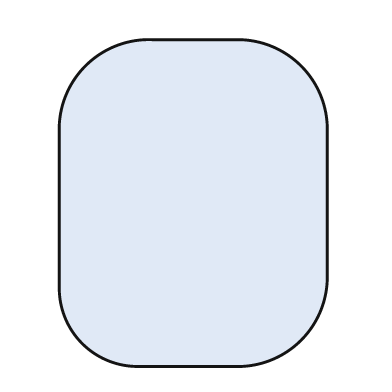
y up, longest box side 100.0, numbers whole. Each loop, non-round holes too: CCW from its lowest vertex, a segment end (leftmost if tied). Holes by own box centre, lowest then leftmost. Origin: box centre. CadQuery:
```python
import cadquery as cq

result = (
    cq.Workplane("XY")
    .moveTo(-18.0, -50.0)
    .lineTo(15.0, -50.0)
    .threePointArc((33.0, -42.0), (41.0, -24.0))
    .lineTo(41.0, 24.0)
    .threePointArc((33.0, 42.0), (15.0, 50.0))
    .lineTo(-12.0, 50.0)
    .threePointArc((-33.0, 42.0), (-41.0, 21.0))
    .lineTo(-41.0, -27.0)
    .threePointArc((-34.0, -43.0), (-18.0, -50.0))
    .close()
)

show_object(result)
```